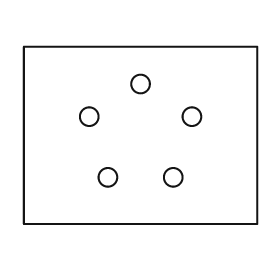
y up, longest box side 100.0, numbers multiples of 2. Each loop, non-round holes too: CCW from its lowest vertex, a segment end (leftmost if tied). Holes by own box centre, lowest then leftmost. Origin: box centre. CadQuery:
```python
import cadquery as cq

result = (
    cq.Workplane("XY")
    .moveTo(-50.0, -38.0)
    .lineTo(50.0, -38.0)
    .lineTo(50.0, 38.0)
    .lineTo(-50.0, 38.0)
    .close()
    .moveTo(-14.0, -18.0)
    .circle(4.0)
    .moveTo(14.0, -18.0)
    .circle(4.0)
    .moveTo(-22.0, 8.0)
    .circle(4.0)
    .moveTo(22.0, 8.0)
    .circle(4.0)
    .moveTo(0.0, 22.0)
    .circle(4.0)
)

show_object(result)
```